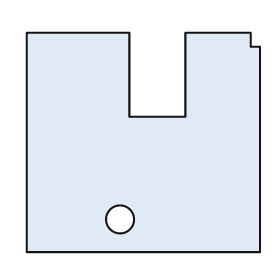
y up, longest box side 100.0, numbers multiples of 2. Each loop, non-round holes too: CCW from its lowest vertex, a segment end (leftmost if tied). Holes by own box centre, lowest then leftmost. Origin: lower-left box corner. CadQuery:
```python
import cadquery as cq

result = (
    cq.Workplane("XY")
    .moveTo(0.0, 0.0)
    .lineTo(100.0, 0.0)
    .lineTo(100.0, 88.0)
    .lineTo(96.0, 88.0)
    .lineTo(96.0, 94.0)
    .lineTo(68.0, 94.0)
    .lineTo(68.0, 58.0)
    .lineTo(44.0, 58.0)
    .lineTo(44.0, 94.0)
    .lineTo(0.0, 94.0)
    .close()
    .moveTo(40.0, 14.0)
    .circle(6.0)
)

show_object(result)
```